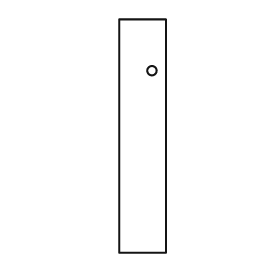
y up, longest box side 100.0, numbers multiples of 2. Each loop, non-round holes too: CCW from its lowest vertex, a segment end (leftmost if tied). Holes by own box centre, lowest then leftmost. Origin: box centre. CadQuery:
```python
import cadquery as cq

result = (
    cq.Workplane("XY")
    .moveTo(-10.0, -50.0)
    .lineTo(10.0, -50.0)
    .lineTo(10.0, 50.0)
    .lineTo(-10.0, 50.0)
    .close()
    .moveTo(4.0, 28.0)
    .circle(2.0)
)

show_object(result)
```